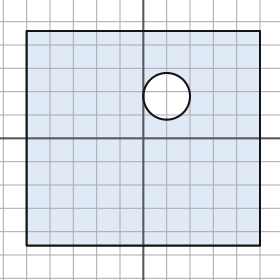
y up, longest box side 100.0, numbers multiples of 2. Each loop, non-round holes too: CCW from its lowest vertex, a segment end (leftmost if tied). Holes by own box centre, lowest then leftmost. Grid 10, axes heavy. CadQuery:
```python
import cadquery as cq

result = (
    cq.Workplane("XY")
    .moveTo(-50.0, -46.0)
    .lineTo(50.0, -46.0)
    .lineTo(50.0, 46.0)
    .lineTo(-50.0, 46.0)
    .close()
    .moveTo(10.0, 18.0)
    .circle(10.0)
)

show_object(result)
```